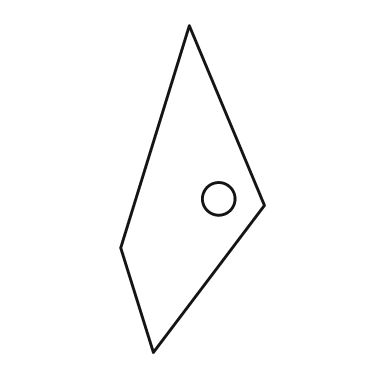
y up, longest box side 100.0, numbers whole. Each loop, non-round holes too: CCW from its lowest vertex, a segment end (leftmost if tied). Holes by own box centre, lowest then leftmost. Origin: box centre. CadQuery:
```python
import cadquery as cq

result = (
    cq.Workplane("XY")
    .moveTo(-12.0, -50.0)
    .lineTo(22.0, -5.0)
    .lineTo(-1.0, 50.0)
    .lineTo(-22.0, -18.0)
    .close()
    .moveTo(8.0, -3.0)
    .circle(5.0)
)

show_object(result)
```